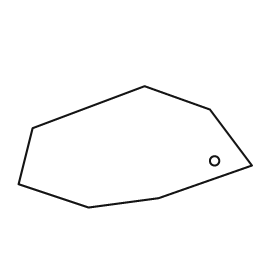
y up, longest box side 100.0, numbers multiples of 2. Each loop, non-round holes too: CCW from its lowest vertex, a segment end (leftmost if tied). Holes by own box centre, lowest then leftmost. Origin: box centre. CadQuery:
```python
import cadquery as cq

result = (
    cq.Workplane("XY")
    .moveTo(-20.0, -26.0)
    .lineTo(10.0, -22.0)
    .lineTo(50.0, -8.0)
    .lineTo(32.0, 16.0)
    .lineTo(4.0, 26.0)
    .lineTo(-44.0, 8.0)
    .lineTo(-50.0, -16.0)
    .close()
    .moveTo(34.0, -6.0)
    .circle(2.0)
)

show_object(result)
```